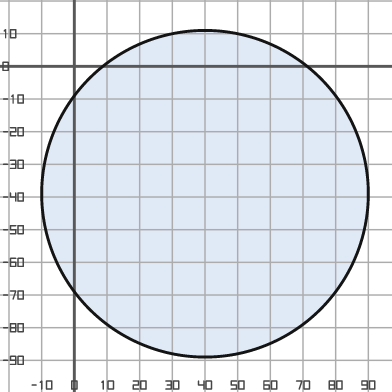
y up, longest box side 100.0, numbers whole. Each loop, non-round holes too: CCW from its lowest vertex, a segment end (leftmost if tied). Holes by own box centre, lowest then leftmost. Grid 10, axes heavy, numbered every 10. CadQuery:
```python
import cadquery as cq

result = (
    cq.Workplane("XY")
    .moveTo(40.0, -39.0)
    .circle(50.0)
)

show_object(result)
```